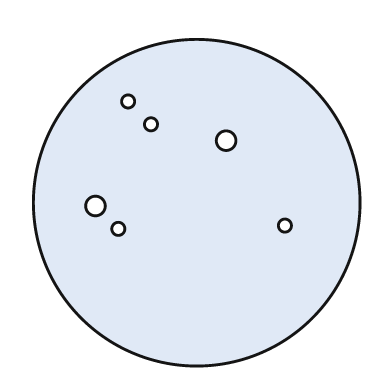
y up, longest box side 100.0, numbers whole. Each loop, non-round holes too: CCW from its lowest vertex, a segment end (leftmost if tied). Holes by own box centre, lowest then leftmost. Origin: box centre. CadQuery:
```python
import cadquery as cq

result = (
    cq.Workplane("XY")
    .moveTo(0.0, 0.0)
    .circle(50.0)
    .moveTo(-24.0, -8.0)
    .circle(2.0)
    .moveTo(27.0, -7.0)
    .circle(2.0)
    .moveTo(-31.0, -1.0)
    .circle(3.0)
    .moveTo(9.0, 19.0)
    .circle(3.0)
    .moveTo(-14.0, 24.0)
    .circle(2.0)
    .moveTo(-21.0, 31.0)
    .circle(2.0)
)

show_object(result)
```